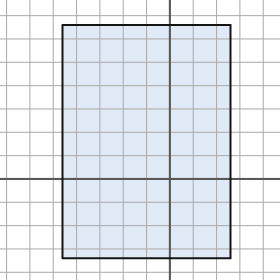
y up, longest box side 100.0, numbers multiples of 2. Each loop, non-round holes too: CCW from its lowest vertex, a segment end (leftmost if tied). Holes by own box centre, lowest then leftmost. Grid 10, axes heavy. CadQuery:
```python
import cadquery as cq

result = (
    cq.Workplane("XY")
    .moveTo(-46.0, -34.0)
    .lineTo(26.0, -34.0)
    .lineTo(26.0, 66.0)
    .lineTo(-46.0, 66.0)
    .close()
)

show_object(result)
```